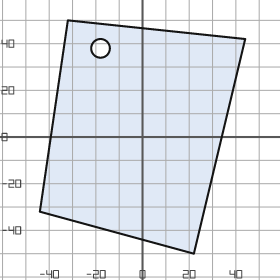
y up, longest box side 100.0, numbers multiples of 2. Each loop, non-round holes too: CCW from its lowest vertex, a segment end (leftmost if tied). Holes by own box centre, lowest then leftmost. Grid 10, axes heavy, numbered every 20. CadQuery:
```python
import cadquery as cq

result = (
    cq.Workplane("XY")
    .moveTo(22.0, -50.0)
    .lineTo(44.0, 42.0)
    .lineTo(-32.0, 50.0)
    .lineTo(-44.0, -32.0)
    .close()
    .moveTo(-18.0, 38.0)
    .circle(4.0)
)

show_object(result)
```